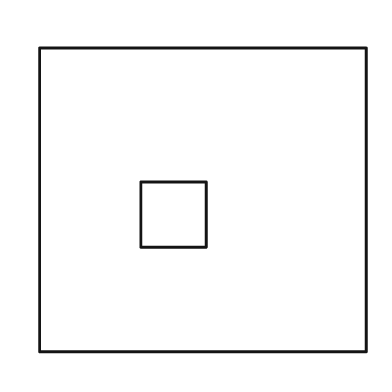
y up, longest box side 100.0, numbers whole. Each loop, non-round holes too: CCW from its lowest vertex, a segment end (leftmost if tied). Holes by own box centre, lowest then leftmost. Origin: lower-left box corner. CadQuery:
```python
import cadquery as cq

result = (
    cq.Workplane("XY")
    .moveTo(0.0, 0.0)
    .lineTo(100.0, 0.0)
    .lineTo(100.0, 93.0)
    .lineTo(0.0, 93.0)
    .close()
    .moveTo(31.0, 32.0)
    .lineTo(51.0, 32.0)
    .lineTo(51.0, 52.0)
    .lineTo(31.0, 52.0)
    .close()
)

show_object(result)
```